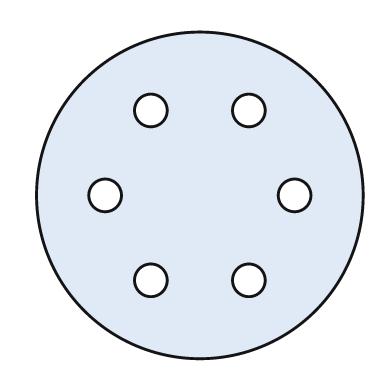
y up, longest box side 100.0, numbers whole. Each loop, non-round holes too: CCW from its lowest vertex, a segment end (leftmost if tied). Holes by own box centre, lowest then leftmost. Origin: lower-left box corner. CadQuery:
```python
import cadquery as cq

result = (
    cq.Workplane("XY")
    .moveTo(50.0, 50.0)
    .circle(50.0)
    .moveTo(35.0, 24.0)
    .circle(5.0)
    .moveTo(65.0, 24.0)
    .circle(5.0)
    .moveTo(21.0, 50.0)
    .circle(5.0)
    .moveTo(79.0, 50.0)
    .circle(5.0)
    .moveTo(35.0, 76.0)
    .circle(5.0)
    .moveTo(65.0, 76.0)
    .circle(5.0)
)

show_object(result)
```